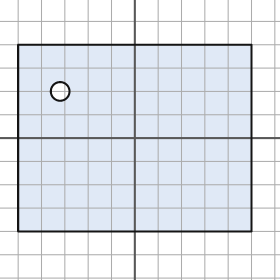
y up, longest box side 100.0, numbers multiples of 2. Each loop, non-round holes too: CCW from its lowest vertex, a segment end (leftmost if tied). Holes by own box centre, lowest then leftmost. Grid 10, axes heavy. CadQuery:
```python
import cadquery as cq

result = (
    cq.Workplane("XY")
    .moveTo(-50.0, -40.0)
    .lineTo(50.0, -40.0)
    .lineTo(50.0, 40.0)
    .lineTo(-50.0, 40.0)
    .close()
    .moveTo(-32.0, 20.0)
    .circle(4.0)
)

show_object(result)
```